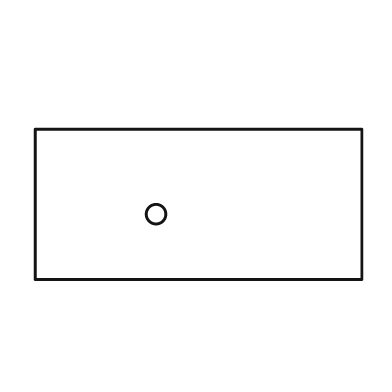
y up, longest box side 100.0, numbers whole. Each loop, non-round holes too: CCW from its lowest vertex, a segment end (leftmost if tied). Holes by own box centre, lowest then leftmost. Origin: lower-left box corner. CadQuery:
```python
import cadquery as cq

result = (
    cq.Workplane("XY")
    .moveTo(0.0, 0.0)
    .lineTo(100.0, 0.0)
    .lineTo(100.0, 46.0)
    .lineTo(0.0, 46.0)
    .close()
    .moveTo(37.0, 20.0)
    .circle(3.0)
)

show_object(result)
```